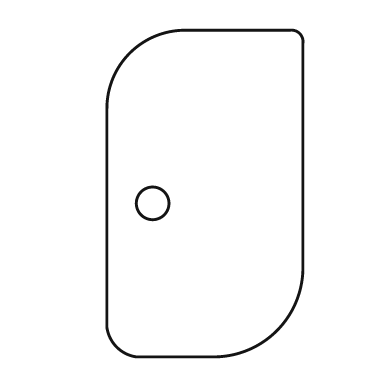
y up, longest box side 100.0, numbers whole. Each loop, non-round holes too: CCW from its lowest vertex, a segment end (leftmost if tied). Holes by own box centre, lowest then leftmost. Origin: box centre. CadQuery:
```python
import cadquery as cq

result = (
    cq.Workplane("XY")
    .moveTo(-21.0, -50.0)
    .lineTo(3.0, -50.0)
    .threePointArc((22.0, -42.0), (30.0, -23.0))
    .lineTo(30.0, 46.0)
    .threePointArc((29.0, 49.0), (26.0, 50.0))
    .lineTo(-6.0, 50.0)
    .threePointArc((-23.0, 43.0), (-30.0, 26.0))
    .lineTo(-30.0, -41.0)
    .threePointArc((-27.0, -47.0), (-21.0, -50.0))
    .close()
    .moveTo(-16.0, -3.0)
    .circle(5.0)
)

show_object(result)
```